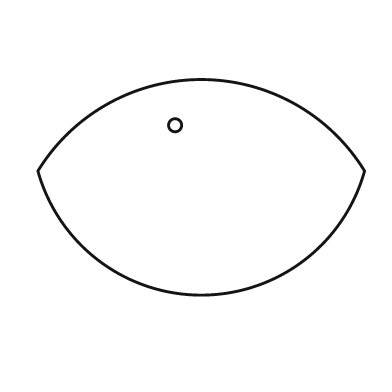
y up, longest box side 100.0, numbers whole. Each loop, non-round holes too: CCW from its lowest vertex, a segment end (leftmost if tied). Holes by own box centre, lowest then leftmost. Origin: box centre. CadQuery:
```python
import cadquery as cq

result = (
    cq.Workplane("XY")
    .moveTo(-50.0, 5.0)
    .threePointArc((0.0, -33.0), (50.0, 5.0))
    .threePointArc((0.0, 33.0), (-50.0, 5.0))
    .close()
    .moveTo(-8.0, 19.0)
    .circle(2.0)
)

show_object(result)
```